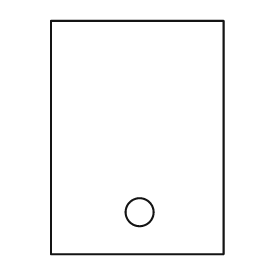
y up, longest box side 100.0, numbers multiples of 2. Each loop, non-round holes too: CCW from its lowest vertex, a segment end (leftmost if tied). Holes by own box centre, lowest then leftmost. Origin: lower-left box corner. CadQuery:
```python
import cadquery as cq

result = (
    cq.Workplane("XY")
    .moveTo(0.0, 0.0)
    .lineTo(74.0, 0.0)
    .lineTo(74.0, 100.0)
    .lineTo(0.0, 100.0)
    .close()
    .moveTo(38.0, 18.0)
    .circle(6.0)
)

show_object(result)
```